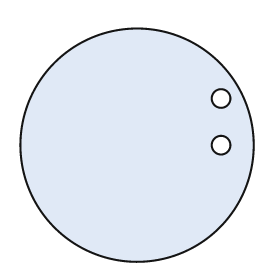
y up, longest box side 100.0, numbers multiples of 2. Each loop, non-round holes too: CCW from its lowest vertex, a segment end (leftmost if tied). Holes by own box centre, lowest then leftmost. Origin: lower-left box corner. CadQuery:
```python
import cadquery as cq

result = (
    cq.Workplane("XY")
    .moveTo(50.0, 50.0)
    .circle(50.0)
    .moveTo(86.0, 50.0)
    .circle(4.0)
    .moveTo(86.0, 70.0)
    .circle(4.0)
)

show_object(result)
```